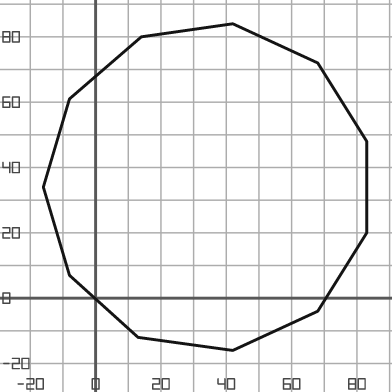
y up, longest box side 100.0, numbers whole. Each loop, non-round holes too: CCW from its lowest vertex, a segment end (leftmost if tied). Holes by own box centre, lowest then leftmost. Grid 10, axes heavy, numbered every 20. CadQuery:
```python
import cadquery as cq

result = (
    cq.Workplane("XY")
    .moveTo(42.0, -16.0)
    .lineTo(68.0, -4.0)
    .lineTo(83.0, 20.0)
    .lineTo(83.0, 48.0)
    .lineTo(68.0, 72.0)
    .lineTo(42.0, 84.0)
    .lineTo(14.0, 80.0)
    .lineTo(-8.0, 61.0)
    .lineTo(-16.0, 34.0)
    .lineTo(-8.0, 7.0)
    .lineTo(13.0, -12.0)
    .close()
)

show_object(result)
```